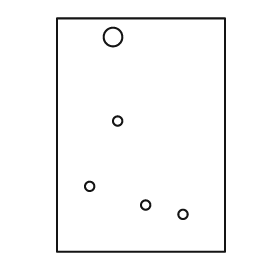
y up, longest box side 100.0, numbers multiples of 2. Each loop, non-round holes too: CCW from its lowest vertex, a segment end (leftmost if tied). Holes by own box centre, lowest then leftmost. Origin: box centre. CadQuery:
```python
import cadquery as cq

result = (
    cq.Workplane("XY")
    .moveTo(-36.0, -50.0)
    .lineTo(36.0, -50.0)
    .lineTo(36.0, 50.0)
    .lineTo(-36.0, 50.0)
    .close()
    .moveTo(18.0, -34.0)
    .circle(2.0)
    .moveTo(2.0, -30.0)
    .circle(2.0)
    .moveTo(-22.0, -22.0)
    .circle(2.0)
    .moveTo(-10.0, 6.0)
    .circle(2.0)
    .moveTo(-12.0, 42.0)
    .circle(4.0)
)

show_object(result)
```